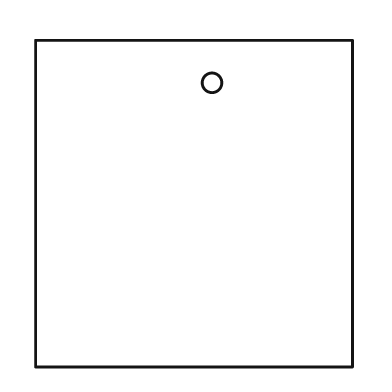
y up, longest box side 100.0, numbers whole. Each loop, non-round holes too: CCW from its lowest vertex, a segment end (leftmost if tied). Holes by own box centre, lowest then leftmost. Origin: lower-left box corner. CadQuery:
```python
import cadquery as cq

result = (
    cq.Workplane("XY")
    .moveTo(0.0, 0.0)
    .lineTo(97.0, 0.0)
    .lineTo(97.0, 100.0)
    .lineTo(0.0, 100.0)
    .close()
    .moveTo(54.0, 87.0)
    .circle(3.0)
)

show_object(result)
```